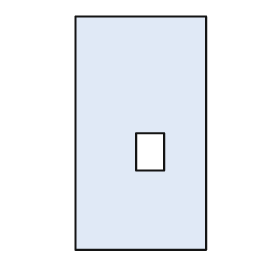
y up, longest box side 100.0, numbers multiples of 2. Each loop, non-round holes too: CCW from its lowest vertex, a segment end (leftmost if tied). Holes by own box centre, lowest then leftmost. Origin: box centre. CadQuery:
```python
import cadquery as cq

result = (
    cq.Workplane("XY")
    .moveTo(-28.0, -50.0)
    .lineTo(28.0, -50.0)
    .lineTo(28.0, 50.0)
    .lineTo(-28.0, 50.0)
    .close()
    .moveTo(-2.0, -16.0)
    .lineTo(10.0, -16.0)
    .lineTo(10.0, 0.0)
    .lineTo(-2.0, 0.0)
    .close()
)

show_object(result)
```